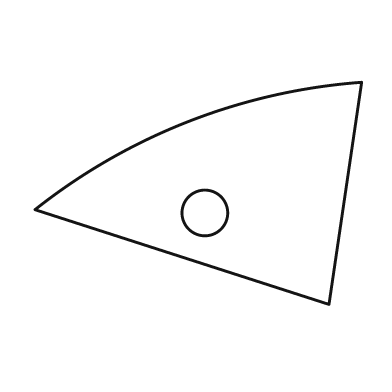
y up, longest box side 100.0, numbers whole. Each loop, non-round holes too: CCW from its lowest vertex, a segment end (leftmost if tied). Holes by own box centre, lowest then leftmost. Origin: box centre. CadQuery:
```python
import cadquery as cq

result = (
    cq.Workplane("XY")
    .moveTo(40.0, -34.0)
    .lineTo(50.0, 34.0)
    .threePointArc((-3.0, 22.0), (-50.0, -5.0))
    .close()
    .moveTo(2.0, -6.0)
    .circle(7.0)
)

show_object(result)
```